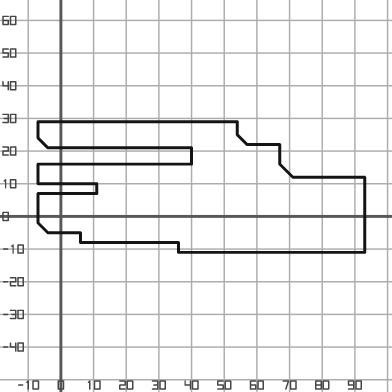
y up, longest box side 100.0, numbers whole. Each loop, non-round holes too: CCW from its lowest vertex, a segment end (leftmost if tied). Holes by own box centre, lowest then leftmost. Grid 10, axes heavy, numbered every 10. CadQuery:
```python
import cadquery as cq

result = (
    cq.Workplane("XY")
    .moveTo(36.0, -11.0)
    .lineTo(93.0, -11.0)
    .lineTo(93.0, 12.0)
    .lineTo(71.0, 12.0)
    .lineTo(67.0, 16.0)
    .lineTo(67.0, 22.0)
    .lineTo(57.0, 22.0)
    .lineTo(54.0, 25.0)
    .lineTo(54.0, 29.0)
    .lineTo(-7.0, 29.0)
    .lineTo(-7.0, 24.0)
    .lineTo(-4.0, 21.0)
    .lineTo(40.0, 21.0)
    .lineTo(40.0, 16.0)
    .lineTo(-7.0, 16.0)
    .lineTo(-7.0, 10.0)
    .lineTo(11.0, 10.0)
    .lineTo(11.0, 7.0)
    .lineTo(-7.0, 7.0)
    .lineTo(-7.0, -2.0)
    .lineTo(-4.0, -5.0)
    .lineTo(6.0, -5.0)
    .lineTo(6.0, -8.0)
    .lineTo(36.0, -8.0)
    .close()
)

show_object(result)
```